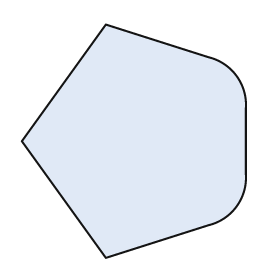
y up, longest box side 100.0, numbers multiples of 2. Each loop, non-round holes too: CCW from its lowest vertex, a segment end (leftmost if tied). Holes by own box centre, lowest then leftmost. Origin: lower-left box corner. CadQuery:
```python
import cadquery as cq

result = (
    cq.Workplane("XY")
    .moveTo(36.0, 0.0)
    .lineTo(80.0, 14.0)
    .threePointArc((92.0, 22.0), (96.0, 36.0))
    .lineTo(96.0, 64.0)
    .threePointArc((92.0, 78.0), (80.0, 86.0))
    .lineTo(36.0, 100.0)
    .lineTo(0.0, 50.0)
    .close()
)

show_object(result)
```